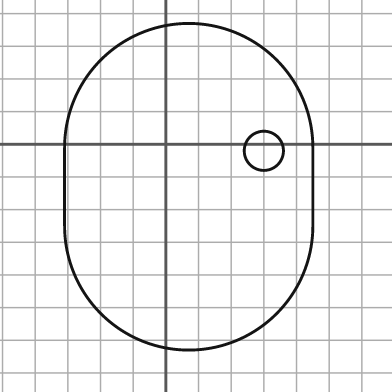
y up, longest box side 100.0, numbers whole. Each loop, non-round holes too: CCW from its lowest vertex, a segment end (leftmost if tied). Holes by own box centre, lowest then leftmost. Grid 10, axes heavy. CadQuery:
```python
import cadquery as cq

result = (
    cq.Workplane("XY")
    .moveTo(-31.0, -25.0)
    .threePointArc((7.0, -63.0), (45.0, -25.0))
    .lineTo(45.0, -1.0)
    .threePointArc((7.0, 37.0), (-31.0, -1.0))
    .close()
    .moveTo(30.0, -2.0)
    .circle(6.0)
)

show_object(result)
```